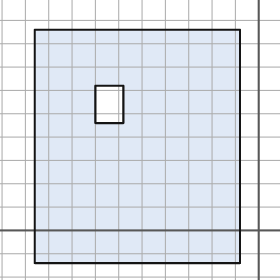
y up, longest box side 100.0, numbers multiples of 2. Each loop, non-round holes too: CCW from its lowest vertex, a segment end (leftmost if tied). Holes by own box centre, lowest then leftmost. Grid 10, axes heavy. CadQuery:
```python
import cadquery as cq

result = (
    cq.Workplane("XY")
    .moveTo(-96.0, -14.0)
    .lineTo(-8.0, -14.0)
    .lineTo(-8.0, 86.0)
    .lineTo(-96.0, 86.0)
    .close()
    .moveTo(-70.0, 46.0)
    .lineTo(-58.0, 46.0)
    .lineTo(-58.0, 62.0)
    .lineTo(-70.0, 62.0)
    .close()
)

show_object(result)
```